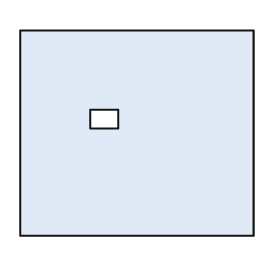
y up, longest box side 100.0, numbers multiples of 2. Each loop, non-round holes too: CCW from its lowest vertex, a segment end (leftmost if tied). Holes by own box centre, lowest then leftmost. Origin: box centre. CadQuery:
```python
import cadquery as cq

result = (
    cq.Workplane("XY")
    .moveTo(-50.0, -44.0)
    .lineTo(50.0, -44.0)
    .lineTo(50.0, 44.0)
    .lineTo(-50.0, 44.0)
    .close()
    .moveTo(-20.0, 2.0)
    .lineTo(-8.0, 2.0)
    .lineTo(-8.0, 10.0)
    .lineTo(-20.0, 10.0)
    .close()
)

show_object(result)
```